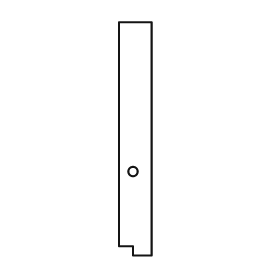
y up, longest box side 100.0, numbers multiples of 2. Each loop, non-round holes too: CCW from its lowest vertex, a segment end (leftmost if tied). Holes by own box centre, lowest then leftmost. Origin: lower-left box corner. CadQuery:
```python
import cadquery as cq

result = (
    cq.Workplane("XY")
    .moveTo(6.0, 0.0)
    .lineTo(14.0, 0.0)
    .lineTo(14.0, 100.0)
    .lineTo(0.0, 100.0)
    .lineTo(0.0, 4.0)
    .lineTo(6.0, 4.0)
    .close()
    .moveTo(6.0, 36.0)
    .circle(2.0)
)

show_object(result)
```